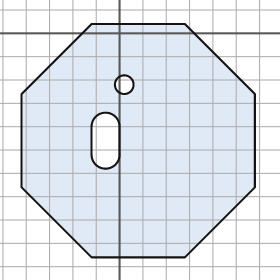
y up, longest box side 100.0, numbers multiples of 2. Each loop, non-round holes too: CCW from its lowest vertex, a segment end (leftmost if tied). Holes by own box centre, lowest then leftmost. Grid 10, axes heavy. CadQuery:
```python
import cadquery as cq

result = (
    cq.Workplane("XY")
    .moveTo(-12.0, -96.0)
    .lineTo(28.0, -96.0)
    .lineTo(58.0, -66.0)
    .lineTo(58.0, -26.0)
    .lineTo(28.0, 4.0)
    .lineTo(-12.0, 4.0)
    .lineTo(-42.0, -26.0)
    .lineTo(-42.0, -66.0)
    .close()
    .moveTo(-12.0, -52.0)
    .threePointArc((-6.0, -58.0), (0.0, -52.0))
    .lineTo(0.0, -40.0)
    .threePointArc((-6.0, -34.0), (-12.0, -40.0))
    .close()
    .moveTo(2.0, -22.0)
    .circle(4.0)
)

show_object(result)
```